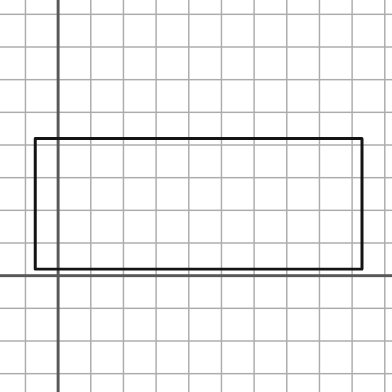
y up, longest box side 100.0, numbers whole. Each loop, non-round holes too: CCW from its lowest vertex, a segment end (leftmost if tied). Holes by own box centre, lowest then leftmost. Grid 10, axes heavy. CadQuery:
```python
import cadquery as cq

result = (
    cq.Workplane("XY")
    .moveTo(-7.0, 2.0)
    .lineTo(93.0, 2.0)
    .lineTo(93.0, 42.0)
    .lineTo(-7.0, 42.0)
    .close()
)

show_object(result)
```